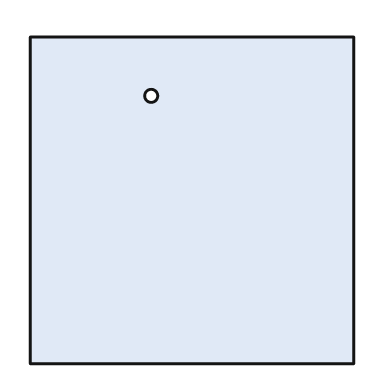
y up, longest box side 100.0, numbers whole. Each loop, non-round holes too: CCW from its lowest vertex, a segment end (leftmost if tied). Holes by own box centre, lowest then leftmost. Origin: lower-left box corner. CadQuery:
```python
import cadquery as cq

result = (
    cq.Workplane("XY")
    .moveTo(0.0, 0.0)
    .lineTo(99.0, 0.0)
    .lineTo(99.0, 100.0)
    .lineTo(0.0, 100.0)
    .close()
    .moveTo(37.0, 82.0)
    .circle(2.0)
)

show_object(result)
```